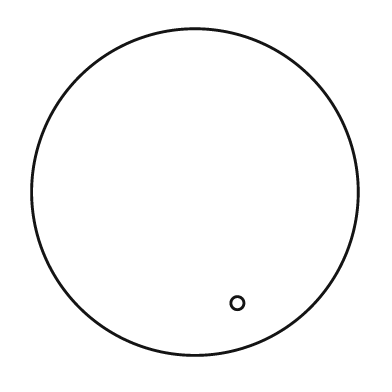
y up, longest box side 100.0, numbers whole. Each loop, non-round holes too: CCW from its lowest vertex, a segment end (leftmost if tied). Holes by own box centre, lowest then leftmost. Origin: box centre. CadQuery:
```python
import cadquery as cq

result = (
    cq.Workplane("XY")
    .moveTo(0.0, 0.0)
    .circle(50.0)
    .moveTo(13.0, -34.0)
    .circle(2.0)
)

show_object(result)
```